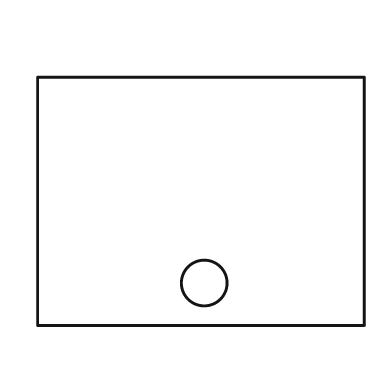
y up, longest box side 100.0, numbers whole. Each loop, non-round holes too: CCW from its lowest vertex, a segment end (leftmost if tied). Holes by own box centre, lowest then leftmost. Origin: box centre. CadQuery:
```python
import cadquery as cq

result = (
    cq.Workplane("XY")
    .moveTo(-50.0, -38.0)
    .lineTo(50.0, -38.0)
    .lineTo(50.0, 38.0)
    .lineTo(-50.0, 38.0)
    .close()
    .moveTo(1.0, -25.0)
    .circle(7.0)
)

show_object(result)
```